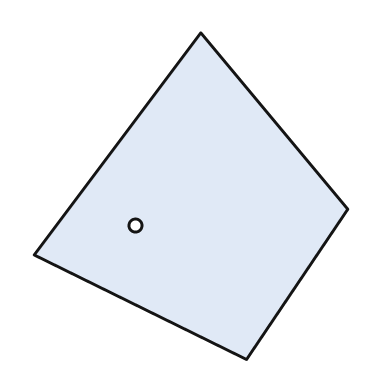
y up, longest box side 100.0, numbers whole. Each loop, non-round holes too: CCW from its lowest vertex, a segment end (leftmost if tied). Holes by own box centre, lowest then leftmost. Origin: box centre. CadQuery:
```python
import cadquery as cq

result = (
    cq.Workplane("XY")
    .moveTo(17.0, -50.0)
    .lineTo(48.0, -4.0)
    .lineTo(3.0, 50.0)
    .lineTo(-48.0, -18.0)
    .close()
    .moveTo(-17.0, -9.0)
    .circle(2.0)
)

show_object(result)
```